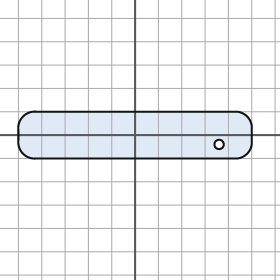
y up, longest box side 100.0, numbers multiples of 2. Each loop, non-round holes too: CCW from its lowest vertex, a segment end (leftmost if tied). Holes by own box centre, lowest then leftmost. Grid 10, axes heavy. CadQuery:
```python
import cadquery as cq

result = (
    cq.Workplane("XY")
    .moveTo(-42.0, -10.0)
    .lineTo(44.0, -10.0)
    .threePointArc((48.0, -8.0), (50.0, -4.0))
    .lineTo(50.0, 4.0)
    .threePointArc((48.0, 8.0), (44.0, 10.0))
    .lineTo(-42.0, 10.0)
    .threePointArc((-48.0, 8.0), (-50.0, 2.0))
    .lineTo(-50.0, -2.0)
    .threePointArc((-48.0, -8.0), (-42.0, -10.0))
    .close()
    .moveTo(36.0, -4.0)
    .circle(2.0)
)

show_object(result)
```